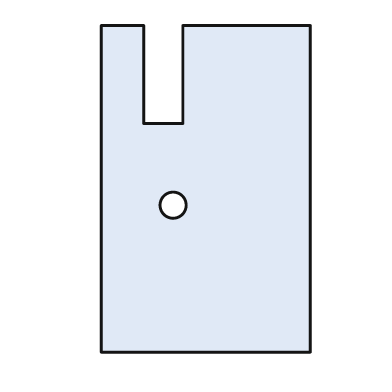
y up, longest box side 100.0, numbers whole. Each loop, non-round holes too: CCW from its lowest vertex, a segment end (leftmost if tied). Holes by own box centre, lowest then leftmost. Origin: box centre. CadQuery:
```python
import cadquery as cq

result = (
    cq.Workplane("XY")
    .moveTo(-32.0, -50.0)
    .lineTo(32.0, -50.0)
    .lineTo(32.0, 50.0)
    .lineTo(-7.0, 50.0)
    .lineTo(-7.0, 20.0)
    .lineTo(-19.0, 20.0)
    .lineTo(-19.0, 50.0)
    .lineTo(-32.0, 50.0)
    .close()
    .moveTo(-10.0, -5.0)
    .circle(4.0)
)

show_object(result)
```